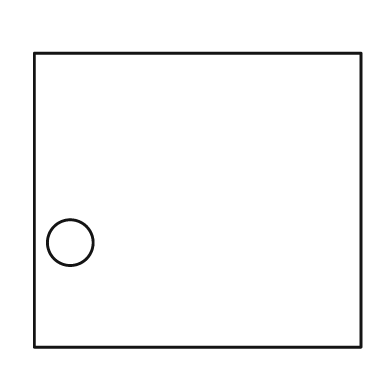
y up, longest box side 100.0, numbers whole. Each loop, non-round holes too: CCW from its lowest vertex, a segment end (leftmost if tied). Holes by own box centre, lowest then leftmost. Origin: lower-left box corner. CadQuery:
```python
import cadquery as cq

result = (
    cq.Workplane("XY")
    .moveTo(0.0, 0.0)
    .lineTo(100.0, 0.0)
    .lineTo(100.0, 90.0)
    .lineTo(0.0, 90.0)
    .close()
    .moveTo(11.0, 32.0)
    .circle(7.0)
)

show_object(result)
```